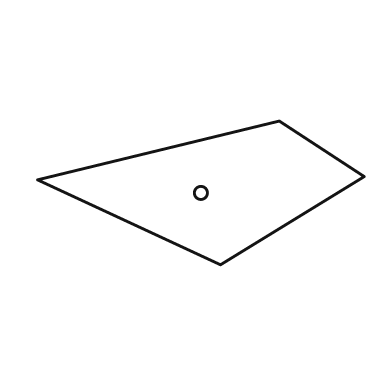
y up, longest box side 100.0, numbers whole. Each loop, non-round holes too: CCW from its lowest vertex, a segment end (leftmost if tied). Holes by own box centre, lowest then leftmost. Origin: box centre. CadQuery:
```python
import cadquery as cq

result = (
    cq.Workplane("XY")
    .moveTo(6.0, -22.0)
    .lineTo(50.0, 5.0)
    .lineTo(24.0, 22.0)
    .lineTo(-50.0, 4.0)
    .close()
    .moveTo(0.0, 0.0)
    .circle(2.0)
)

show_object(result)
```